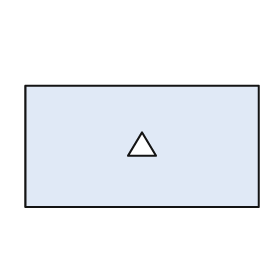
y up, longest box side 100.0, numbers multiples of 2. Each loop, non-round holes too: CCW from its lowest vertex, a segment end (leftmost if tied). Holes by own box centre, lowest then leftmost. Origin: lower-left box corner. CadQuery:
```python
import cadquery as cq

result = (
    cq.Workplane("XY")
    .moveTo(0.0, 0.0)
    .lineTo(100.0, 0.0)
    .lineTo(100.0, 52.0)
    .lineTo(0.0, 52.0)
    .close()
    .moveTo(44.0, 22.0)
    .lineTo(56.0, 22.0)
    .lineTo(50.0, 32.0)
    .close()
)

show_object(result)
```